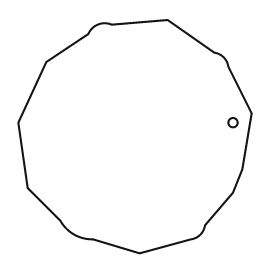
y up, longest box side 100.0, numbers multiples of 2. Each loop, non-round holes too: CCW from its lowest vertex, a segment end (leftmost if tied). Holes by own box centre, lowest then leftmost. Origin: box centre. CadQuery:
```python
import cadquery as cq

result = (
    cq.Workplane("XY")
    .moveTo(2.0, -50.0)
    .lineTo(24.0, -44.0)
    .threePointArc((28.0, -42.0), (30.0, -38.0))
    .lineTo(42.0, -24.0)
    .lineTo(46.0, -14.0)
    .lineTo(50.0, 10.0)
    .lineTo(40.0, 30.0)
    .threePointArc((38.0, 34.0), (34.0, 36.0))
    .lineTo(14.0, 50.0)
    .lineTo(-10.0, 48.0)
    .threePointArc((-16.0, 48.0), (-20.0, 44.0))
    .lineTo(-38.0, 32.0)
    .lineTo(-50.0, 6.0)
    .lineTo(-46.0, -22.0)
    .lineTo(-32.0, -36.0)
    .threePointArc((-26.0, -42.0), (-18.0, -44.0))
    .close()
    .moveTo(42.0, 6.0)
    .circle(2.0)
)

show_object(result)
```